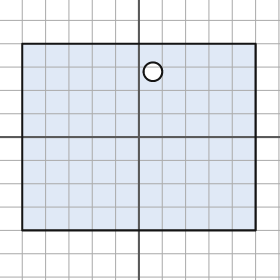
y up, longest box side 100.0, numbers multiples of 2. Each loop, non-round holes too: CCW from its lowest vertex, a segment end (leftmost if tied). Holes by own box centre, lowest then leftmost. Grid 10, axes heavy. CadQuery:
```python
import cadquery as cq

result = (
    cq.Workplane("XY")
    .moveTo(-50.0, -40.0)
    .lineTo(50.0, -40.0)
    .lineTo(50.0, 40.0)
    .lineTo(-50.0, 40.0)
    .close()
    .moveTo(6.0, 28.0)
    .circle(4.0)
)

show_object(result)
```